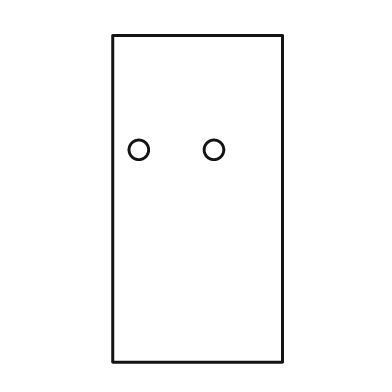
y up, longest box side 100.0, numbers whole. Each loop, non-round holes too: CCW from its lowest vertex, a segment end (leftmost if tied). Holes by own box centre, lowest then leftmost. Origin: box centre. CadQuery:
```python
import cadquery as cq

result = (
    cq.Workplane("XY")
    .moveTo(-26.0, -50.0)
    .lineTo(26.0, -50.0)
    .lineTo(26.0, 50.0)
    .lineTo(-26.0, 50.0)
    .close()
    .moveTo(-18.0, 15.0)
    .circle(3.0)
    .moveTo(5.0, 15.0)
    .circle(3.0)
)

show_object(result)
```